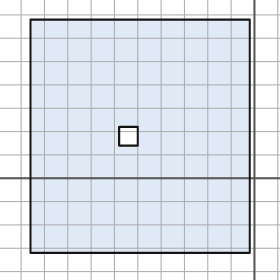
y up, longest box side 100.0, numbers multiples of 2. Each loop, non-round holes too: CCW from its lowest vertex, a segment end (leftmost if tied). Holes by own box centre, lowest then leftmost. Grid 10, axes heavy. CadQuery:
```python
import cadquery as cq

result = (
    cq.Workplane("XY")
    .moveTo(-96.0, -32.0)
    .lineTo(-2.0, -32.0)
    .lineTo(-2.0, 68.0)
    .lineTo(-96.0, 68.0)
    .close()
    .moveTo(-58.0, 14.0)
    .lineTo(-50.0, 14.0)
    .lineTo(-50.0, 22.0)
    .lineTo(-58.0, 22.0)
    .close()
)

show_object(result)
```